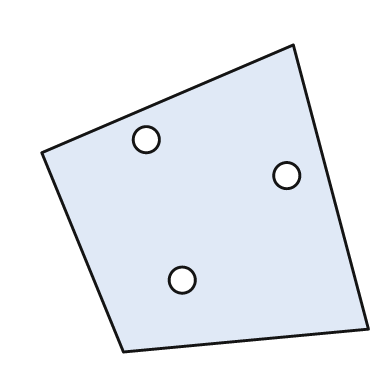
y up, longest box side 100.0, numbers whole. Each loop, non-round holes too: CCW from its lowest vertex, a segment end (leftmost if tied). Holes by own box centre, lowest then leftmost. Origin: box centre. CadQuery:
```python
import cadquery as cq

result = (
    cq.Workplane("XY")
    .moveTo(-25.0, -47.0)
    .lineTo(50.0, -40.0)
    .lineTo(27.0, 47.0)
    .lineTo(-50.0, 14.0)
    .close()
    .moveTo(-7.0, -25.0)
    .circle(4.0)
    .moveTo(25.0, 7.0)
    .circle(4.0)
    .moveTo(-18.0, 18.0)
    .circle(4.0)
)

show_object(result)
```